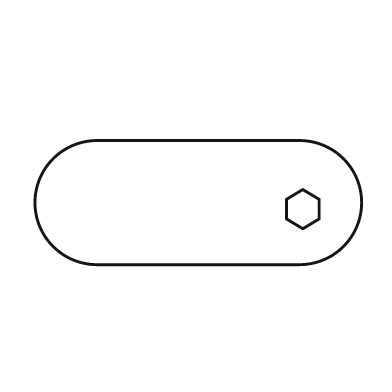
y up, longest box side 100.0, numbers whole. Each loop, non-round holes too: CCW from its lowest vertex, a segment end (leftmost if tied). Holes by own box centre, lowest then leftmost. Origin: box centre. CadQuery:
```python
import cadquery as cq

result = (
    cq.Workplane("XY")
    .moveTo(-31.0, -19.0)
    .lineTo(31.0, -19.0)
    .threePointArc((50.0, 0.0), (31.0, 19.0))
    .lineTo(-31.0, 19.0)
    .threePointArc((-50.0, 0.0), (-31.0, -19.0))
    .close()
    .moveTo(32.0, -8.0)
    .lineTo(37.0, -5.0)
    .lineTo(37.0, 1.0)
    .lineTo(32.0, 4.0)
    .lineTo(27.0, 1.0)
    .lineTo(27.0, -5.0)
    .close()
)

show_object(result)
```